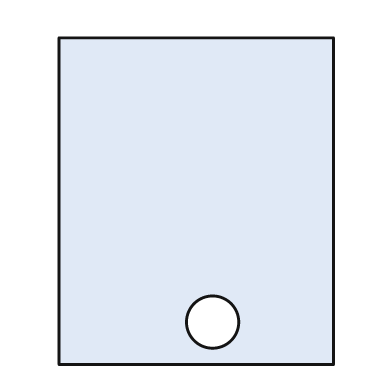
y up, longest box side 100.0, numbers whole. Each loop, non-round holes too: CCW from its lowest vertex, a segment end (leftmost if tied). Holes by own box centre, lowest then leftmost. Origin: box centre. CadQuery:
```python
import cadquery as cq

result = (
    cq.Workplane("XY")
    .moveTo(-42.0, -50.0)
    .lineTo(42.0, -50.0)
    .lineTo(42.0, 50.0)
    .lineTo(-42.0, 50.0)
    .close()
    .moveTo(5.0, -37.0)
    .circle(8.0)
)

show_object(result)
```